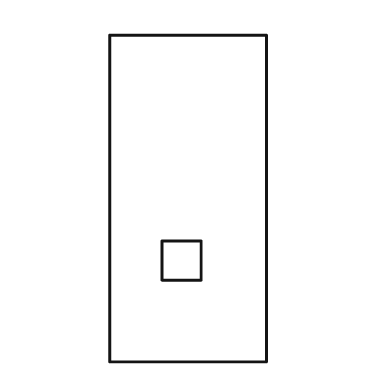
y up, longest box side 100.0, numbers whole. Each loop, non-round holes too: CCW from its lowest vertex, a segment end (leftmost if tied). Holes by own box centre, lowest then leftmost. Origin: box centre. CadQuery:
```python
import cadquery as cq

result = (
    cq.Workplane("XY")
    .moveTo(-24.0, -50.0)
    .lineTo(24.0, -50.0)
    .lineTo(24.0, 50.0)
    .lineTo(-24.0, 50.0)
    .close()
    .moveTo(-8.0, -25.0)
    .lineTo(4.0, -25.0)
    .lineTo(4.0, -13.0)
    .lineTo(-8.0, -13.0)
    .close()
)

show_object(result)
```